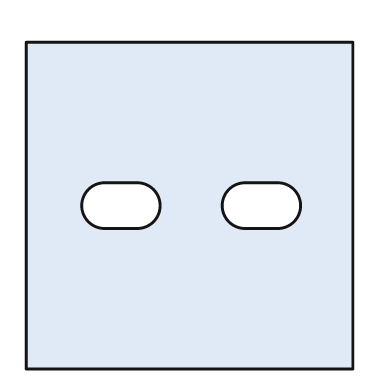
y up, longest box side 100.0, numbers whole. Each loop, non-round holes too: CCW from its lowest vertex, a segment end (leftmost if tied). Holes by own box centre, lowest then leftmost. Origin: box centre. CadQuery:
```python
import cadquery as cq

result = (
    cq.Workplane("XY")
    .moveTo(-50.0, -50.0)
    .lineTo(50.0, -50.0)
    .lineTo(50.0, 50.0)
    .lineTo(-50.0, 50.0)
    .close()
    .moveTo(-26.0, -7.0)
    .lineTo(-16.0, -7.0)
    .threePointArc((-9.0, 0.0), (-16.0, 7.0))
    .lineTo(-26.0, 7.0)
    .threePointArc((-33.0, 0.0), (-26.0, -7.0))
    .close()
    .moveTo(17.0, -7.0)
    .lineTo(27.0, -7.0)
    .threePointArc((34.0, 0.0), (27.0, 7.0))
    .lineTo(17.0, 7.0)
    .threePointArc((10.0, 0.0), (17.0, -7.0))
    .close()
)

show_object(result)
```